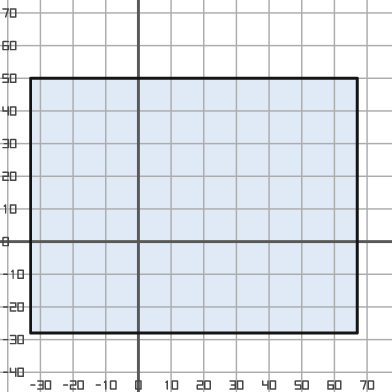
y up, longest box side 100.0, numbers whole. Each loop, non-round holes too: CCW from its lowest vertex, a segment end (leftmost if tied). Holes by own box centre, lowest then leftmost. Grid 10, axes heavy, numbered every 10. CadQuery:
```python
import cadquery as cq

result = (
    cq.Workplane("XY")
    .moveTo(-33.0, -28.0)
    .lineTo(67.0, -28.0)
    .lineTo(67.0, 50.0)
    .lineTo(-33.0, 50.0)
    .close()
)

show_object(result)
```